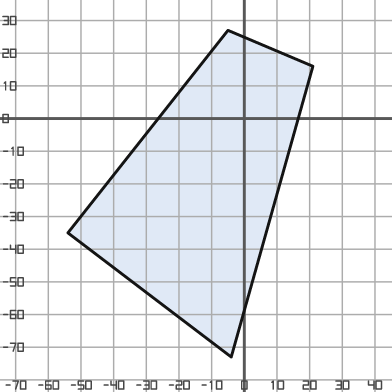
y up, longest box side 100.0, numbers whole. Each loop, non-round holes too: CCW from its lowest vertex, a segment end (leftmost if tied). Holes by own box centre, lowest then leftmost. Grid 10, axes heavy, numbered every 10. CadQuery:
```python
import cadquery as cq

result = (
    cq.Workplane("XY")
    .moveTo(-4.0, -73.0)
    .lineTo(21.0, 16.0)
    .lineTo(-5.0, 27.0)
    .lineTo(-54.0, -35.0)
    .close()
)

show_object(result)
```